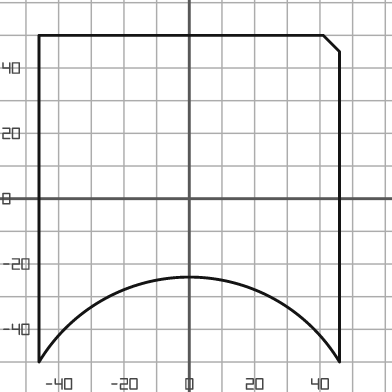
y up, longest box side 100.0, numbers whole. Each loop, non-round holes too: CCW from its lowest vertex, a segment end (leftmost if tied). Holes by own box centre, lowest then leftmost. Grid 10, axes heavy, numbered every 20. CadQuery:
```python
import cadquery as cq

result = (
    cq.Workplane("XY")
    .moveTo(-46.0, -50.0)
    .threePointArc((0.0, -24.0), (46.0, -50.0))
    .lineTo(46.0, 45.0)
    .lineTo(41.0, 50.0)
    .lineTo(-46.0, 50.0)
    .close()
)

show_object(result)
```